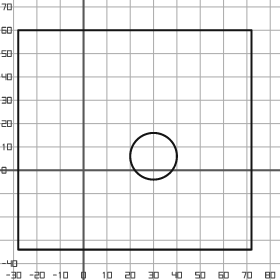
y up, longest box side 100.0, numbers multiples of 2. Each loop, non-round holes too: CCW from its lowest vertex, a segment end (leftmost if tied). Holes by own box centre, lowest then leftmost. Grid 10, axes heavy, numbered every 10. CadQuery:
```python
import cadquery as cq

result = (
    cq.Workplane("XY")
    .moveTo(-28.0, -34.0)
    .lineTo(72.0, -34.0)
    .lineTo(72.0, 60.0)
    .lineTo(-28.0, 60.0)
    .close()
    .moveTo(30.0, 6.0)
    .circle(10.0)
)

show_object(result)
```